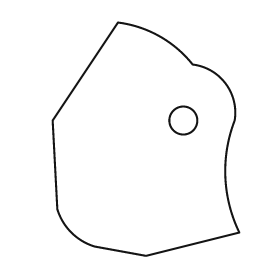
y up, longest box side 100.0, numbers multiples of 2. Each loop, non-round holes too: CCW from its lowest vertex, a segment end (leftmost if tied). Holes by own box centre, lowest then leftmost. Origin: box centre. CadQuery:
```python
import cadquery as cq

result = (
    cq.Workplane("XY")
    .moveTo(0.0, -50.0)
    .lineTo(40.0, -40.0)
    .threePointArc((34.0, -16.0), (38.0, 8.0))
    .threePointArc((34.0, 24.0), (20.0, 32.0))
    .threePointArc((6.0, 44.0), (-12.0, 50.0))
    .lineTo(-40.0, 8.0)
    .lineTo(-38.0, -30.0)
    .threePointArc((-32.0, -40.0), (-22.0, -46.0))
    .close()
    .moveTo(16.0, 8.0)
    .circle(6.0)
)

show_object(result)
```